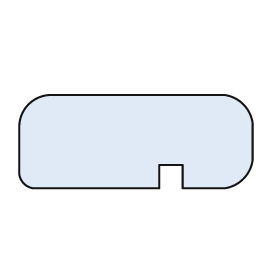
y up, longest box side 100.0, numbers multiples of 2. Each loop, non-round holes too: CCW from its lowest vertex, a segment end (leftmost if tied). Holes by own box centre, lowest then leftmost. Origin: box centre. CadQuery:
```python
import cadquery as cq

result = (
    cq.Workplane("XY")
    .moveTo(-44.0, -20.0)
    .lineTo(10.0, -20.0)
    .lineTo(10.0, -10.0)
    .lineTo(20.0, -10.0)
    .lineTo(20.0, -20.0)
    .lineTo(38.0, -20.0)
    .threePointArc((46.0, -16.0), (50.0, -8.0))
    .lineTo(50.0, 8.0)
    .threePointArc((46.0, 16.0), (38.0, 20.0))
    .lineTo(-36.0, 20.0)
    .threePointArc((-46.0, 16.0), (-50.0, 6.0))
    .lineTo(-50.0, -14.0)
    .threePointArc((-48.0, -18.0), (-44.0, -20.0))
    .close()
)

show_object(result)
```